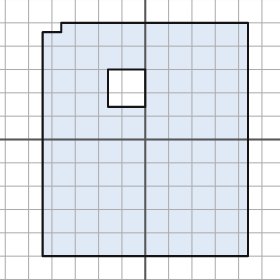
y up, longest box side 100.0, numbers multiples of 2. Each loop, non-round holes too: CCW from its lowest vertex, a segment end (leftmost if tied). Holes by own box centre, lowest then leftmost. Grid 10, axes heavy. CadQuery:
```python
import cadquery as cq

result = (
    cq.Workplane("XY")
    .moveTo(-44.0, -50.0)
    .lineTo(44.0, -50.0)
    .lineTo(44.0, 50.0)
    .lineTo(-36.0, 50.0)
    .lineTo(-36.0, 46.0)
    .lineTo(-44.0, 46.0)
    .close()
    .moveTo(-16.0, 14.0)
    .lineTo(0.0, 14.0)
    .lineTo(0.0, 30.0)
    .lineTo(-16.0, 30.0)
    .close()
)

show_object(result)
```